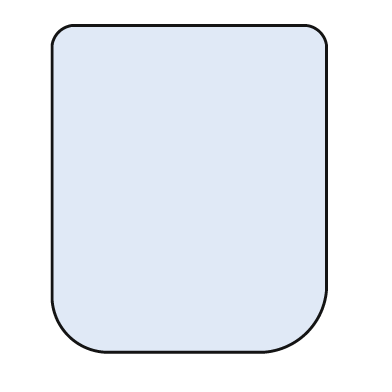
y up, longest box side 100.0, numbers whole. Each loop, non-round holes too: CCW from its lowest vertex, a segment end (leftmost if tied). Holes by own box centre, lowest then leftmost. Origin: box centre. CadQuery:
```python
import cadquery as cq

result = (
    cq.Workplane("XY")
    .moveTo(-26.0, -50.0)
    .lineTo(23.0, -50.0)
    .threePointArc((36.0, -44.0), (42.0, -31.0))
    .lineTo(42.0, 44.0)
    .threePointArc((40.0, 48.0), (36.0, 50.0))
    .lineTo(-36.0, 50.0)
    .threePointArc((-40.0, 48.0), (-42.0, 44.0))
    .lineTo(-42.0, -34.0)
    .threePointArc((-37.0, -45.0), (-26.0, -50.0))
    .close()
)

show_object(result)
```